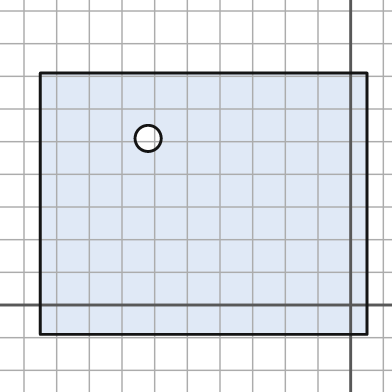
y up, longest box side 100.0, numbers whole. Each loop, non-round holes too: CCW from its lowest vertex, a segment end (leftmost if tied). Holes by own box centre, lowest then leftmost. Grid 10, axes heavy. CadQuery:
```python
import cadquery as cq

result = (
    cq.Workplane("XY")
    .moveTo(-95.0, -9.0)
    .lineTo(5.0, -9.0)
    .lineTo(5.0, 71.0)
    .lineTo(-95.0, 71.0)
    .close()
    .moveTo(-62.0, 51.0)
    .circle(4.0)
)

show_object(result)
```